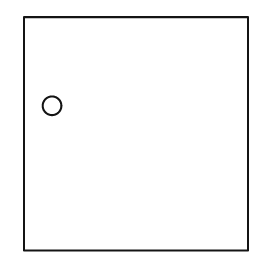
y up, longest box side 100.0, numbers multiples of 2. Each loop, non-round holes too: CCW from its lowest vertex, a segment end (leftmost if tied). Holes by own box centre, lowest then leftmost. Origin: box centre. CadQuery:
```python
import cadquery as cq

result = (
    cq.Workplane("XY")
    .moveTo(-48.0, -50.0)
    .lineTo(48.0, -50.0)
    .lineTo(48.0, 50.0)
    .lineTo(-48.0, 50.0)
    .close()
    .moveTo(-36.0, 12.0)
    .circle(4.0)
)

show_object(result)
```